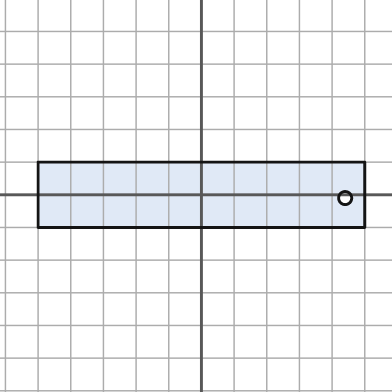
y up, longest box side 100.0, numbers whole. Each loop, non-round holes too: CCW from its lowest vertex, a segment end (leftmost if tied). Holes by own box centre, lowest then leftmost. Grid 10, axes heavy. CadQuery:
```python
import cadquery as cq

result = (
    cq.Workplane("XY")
    .moveTo(-50.0, -10.0)
    .lineTo(50.0, -10.0)
    .lineTo(50.0, 10.0)
    .lineTo(-50.0, 10.0)
    .close()
    .moveTo(44.0, -1.0)
    .circle(2.0)
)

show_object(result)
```